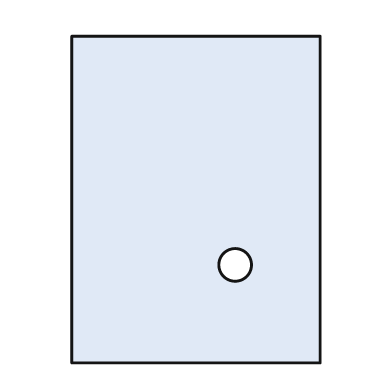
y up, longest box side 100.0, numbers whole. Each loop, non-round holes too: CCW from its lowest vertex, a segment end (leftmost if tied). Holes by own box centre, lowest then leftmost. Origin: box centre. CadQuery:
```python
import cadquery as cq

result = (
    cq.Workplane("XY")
    .moveTo(-38.0, -50.0)
    .lineTo(38.0, -50.0)
    .lineTo(38.0, 50.0)
    .lineTo(-38.0, 50.0)
    .close()
    .moveTo(12.0, -20.0)
    .circle(5.0)
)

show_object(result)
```